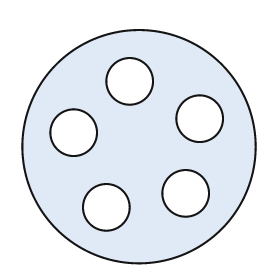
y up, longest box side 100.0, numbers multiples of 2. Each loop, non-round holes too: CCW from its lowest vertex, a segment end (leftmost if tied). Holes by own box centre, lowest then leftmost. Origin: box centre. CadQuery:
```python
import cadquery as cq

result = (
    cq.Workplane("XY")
    .moveTo(0.0, 0.0)
    .circle(50.0)
    .moveTo(-14.0, -26.0)
    .circle(10.0)
    .moveTo(20.0, -20.0)
    .circle(10.0)
    .moveTo(-28.0, 6.0)
    .circle(10.0)
    .moveTo(26.0, 12.0)
    .circle(10.0)
    .moveTo(-4.0, 28.0)
    .circle(10.0)
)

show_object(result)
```